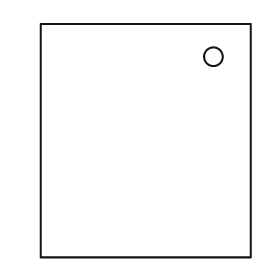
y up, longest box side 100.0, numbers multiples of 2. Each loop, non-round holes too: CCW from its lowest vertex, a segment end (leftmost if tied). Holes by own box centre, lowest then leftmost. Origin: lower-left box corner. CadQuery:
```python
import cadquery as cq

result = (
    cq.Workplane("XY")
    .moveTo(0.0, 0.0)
    .lineTo(90.0, 0.0)
    .lineTo(90.0, 100.0)
    .lineTo(0.0, 100.0)
    .close()
    .moveTo(74.0, 86.0)
    .circle(4.0)
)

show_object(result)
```